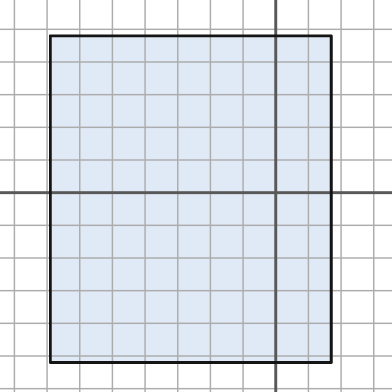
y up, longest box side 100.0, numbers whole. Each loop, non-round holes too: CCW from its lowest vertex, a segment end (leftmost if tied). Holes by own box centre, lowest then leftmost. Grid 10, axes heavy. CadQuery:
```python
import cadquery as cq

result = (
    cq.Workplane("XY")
    .moveTo(-69.0, -52.0)
    .lineTo(17.0, -52.0)
    .lineTo(17.0, 48.0)
    .lineTo(-69.0, 48.0)
    .close()
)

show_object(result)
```